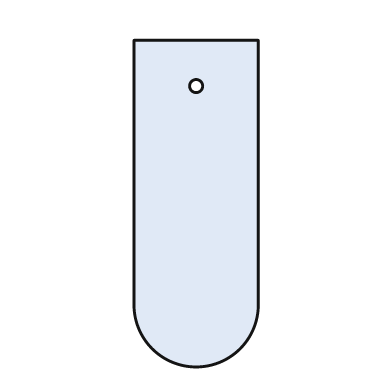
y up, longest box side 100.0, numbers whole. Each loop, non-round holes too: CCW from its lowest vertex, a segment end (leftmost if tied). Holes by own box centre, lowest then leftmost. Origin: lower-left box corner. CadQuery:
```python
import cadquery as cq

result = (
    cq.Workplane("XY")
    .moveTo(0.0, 18.0)
    .threePointArc((19.0, 0.0), (38.0, 18.0))
    .lineTo(38.0, 100.0)
    .lineTo(0.0, 100.0)
    .close()
    .moveTo(19.0, 86.0)
    .circle(2.0)
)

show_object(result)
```